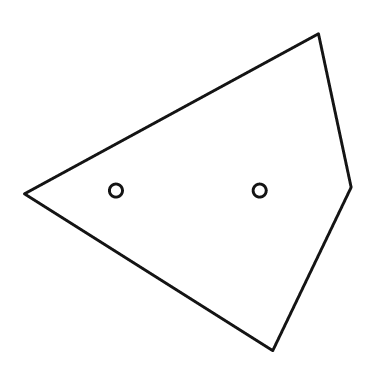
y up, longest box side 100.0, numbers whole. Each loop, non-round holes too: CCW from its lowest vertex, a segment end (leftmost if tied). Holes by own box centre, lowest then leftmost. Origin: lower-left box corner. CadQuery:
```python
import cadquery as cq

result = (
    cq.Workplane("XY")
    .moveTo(76.0, 0.0)
    .lineTo(100.0, 50.0)
    .lineTo(90.0, 97.0)
    .lineTo(0.0, 48.0)
    .close()
    .moveTo(28.0, 49.0)
    .circle(2.0)
    .moveTo(72.0, 49.0)
    .circle(2.0)
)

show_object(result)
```